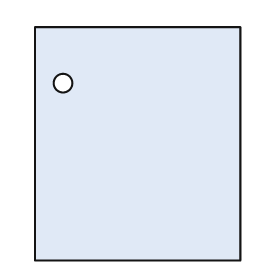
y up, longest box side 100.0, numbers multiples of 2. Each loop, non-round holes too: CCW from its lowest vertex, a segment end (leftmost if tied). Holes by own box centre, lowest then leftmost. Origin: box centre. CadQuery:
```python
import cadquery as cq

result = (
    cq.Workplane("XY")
    .moveTo(-44.0, -50.0)
    .lineTo(44.0, -50.0)
    .lineTo(44.0, 50.0)
    .lineTo(-44.0, 50.0)
    .close()
    .moveTo(-32.0, 26.0)
    .circle(4.0)
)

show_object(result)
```